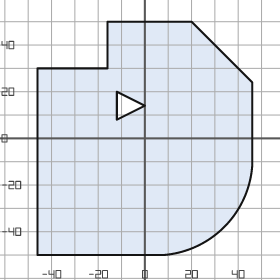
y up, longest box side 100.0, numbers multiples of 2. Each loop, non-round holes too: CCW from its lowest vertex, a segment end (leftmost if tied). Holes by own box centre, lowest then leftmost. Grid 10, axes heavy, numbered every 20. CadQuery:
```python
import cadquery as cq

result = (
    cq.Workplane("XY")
    .moveTo(-46.0, -50.0)
    .lineTo(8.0, -50.0)
    .threePointArc((34.0, -38.0), (46.0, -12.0))
    .lineTo(46.0, 24.0)
    .lineTo(20.0, 50.0)
    .lineTo(-16.0, 50.0)
    .lineTo(-16.0, 30.0)
    .lineTo(-46.0, 30.0)
    .close()
    .moveTo(-12.0, 8.0)
    .lineTo(0.0, 14.0)
    .lineTo(-12.0, 20.0)
    .close()
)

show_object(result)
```